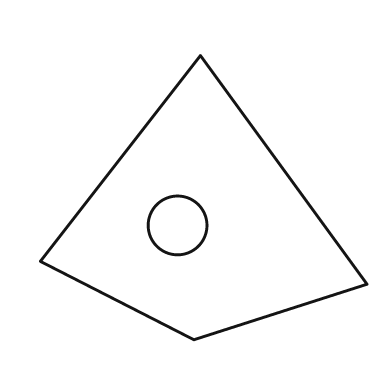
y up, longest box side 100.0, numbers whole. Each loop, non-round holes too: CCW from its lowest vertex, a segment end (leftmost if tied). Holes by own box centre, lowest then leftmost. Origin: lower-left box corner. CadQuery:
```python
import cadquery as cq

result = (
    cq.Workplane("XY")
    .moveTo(47.0, 0.0)
    .lineTo(100.0, 17.0)
    .lineTo(49.0, 87.0)
    .lineTo(0.0, 24.0)
    .close()
    .moveTo(42.0, 35.0)
    .circle(9.0)
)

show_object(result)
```